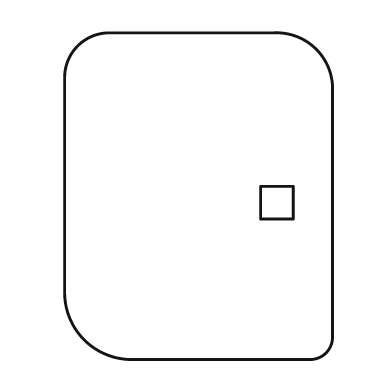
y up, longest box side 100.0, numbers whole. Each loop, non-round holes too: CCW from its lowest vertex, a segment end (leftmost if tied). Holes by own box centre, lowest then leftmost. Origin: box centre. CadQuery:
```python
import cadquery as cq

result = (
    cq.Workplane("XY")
    .moveTo(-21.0, -50.0)
    .lineTo(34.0, -50.0)
    .threePointArc((39.0, -48.0), (41.0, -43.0))
    .lineTo(41.0, 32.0)
    .threePointArc((36.0, 45.0), (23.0, 50.0))
    .lineTo(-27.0, 50.0)
    .threePointArc((-37.0, 46.0), (-41.0, 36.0))
    .lineTo(-41.0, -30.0)
    .threePointArc((-35.0, -44.0), (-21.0, -50.0))
    .close()
    .moveTo(19.0, -7.0)
    .lineTo(29.0, -7.0)
    .lineTo(29.0, 3.0)
    .lineTo(19.0, 3.0)
    .close()
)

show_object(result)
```